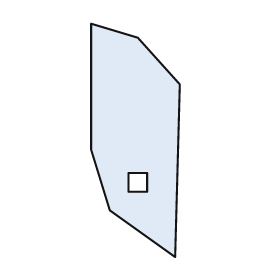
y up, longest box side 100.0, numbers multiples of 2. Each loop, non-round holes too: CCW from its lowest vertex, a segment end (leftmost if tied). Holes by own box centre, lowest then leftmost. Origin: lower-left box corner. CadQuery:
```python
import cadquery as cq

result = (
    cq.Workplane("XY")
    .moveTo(36.0, 0.0)
    .lineTo(38.0, 74.0)
    .lineTo(20.0, 94.0)
    .lineTo(0.0, 100.0)
    .lineTo(0.0, 46.0)
    .lineTo(8.0, 20.0)
    .close()
    .moveTo(16.0, 28.0)
    .lineTo(24.0, 28.0)
    .lineTo(24.0, 36.0)
    .lineTo(16.0, 36.0)
    .close()
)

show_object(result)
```